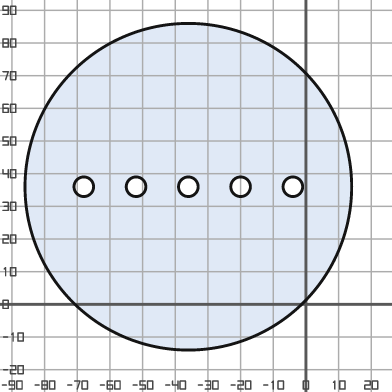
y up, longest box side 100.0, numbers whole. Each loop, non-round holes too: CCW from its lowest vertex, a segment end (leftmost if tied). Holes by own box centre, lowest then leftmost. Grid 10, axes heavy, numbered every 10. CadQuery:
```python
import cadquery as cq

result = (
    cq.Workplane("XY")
    .moveTo(-36.0, 36.0)
    .circle(50.0)
    .moveTo(-68.0, 36.0)
    .circle(3.0)
    .moveTo(-52.0, 36.0)
    .circle(3.0)
    .moveTo(-36.0, 36.0)
    .circle(3.0)
    .moveTo(-20.0, 36.0)
    .circle(3.0)
    .moveTo(-4.0, 36.0)
    .circle(3.0)
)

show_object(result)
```